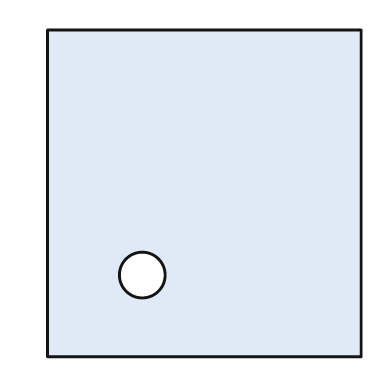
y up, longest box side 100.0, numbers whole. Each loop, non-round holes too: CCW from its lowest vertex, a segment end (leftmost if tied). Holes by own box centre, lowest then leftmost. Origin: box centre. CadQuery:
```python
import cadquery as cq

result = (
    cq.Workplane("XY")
    .moveTo(-48.0, -50.0)
    .lineTo(48.0, -50.0)
    .lineTo(48.0, 50.0)
    .lineTo(-48.0, 50.0)
    .close()
    .moveTo(-19.0, -25.0)
    .circle(7.0)
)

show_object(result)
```